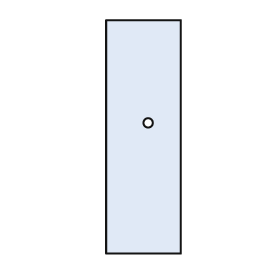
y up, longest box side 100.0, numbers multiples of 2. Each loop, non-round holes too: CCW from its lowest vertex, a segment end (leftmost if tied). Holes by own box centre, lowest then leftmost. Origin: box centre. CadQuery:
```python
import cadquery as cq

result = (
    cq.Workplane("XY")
    .moveTo(-16.0, -50.0)
    .lineTo(16.0, -50.0)
    .lineTo(16.0, 50.0)
    .lineTo(-16.0, 50.0)
    .close()
    .moveTo(2.0, 6.0)
    .circle(2.0)
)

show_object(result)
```